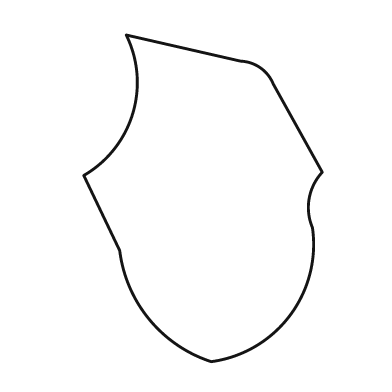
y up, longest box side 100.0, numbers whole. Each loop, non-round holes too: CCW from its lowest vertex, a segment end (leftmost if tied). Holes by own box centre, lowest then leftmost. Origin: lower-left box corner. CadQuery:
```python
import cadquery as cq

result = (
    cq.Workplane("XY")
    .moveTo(39.0, 0.0)
    .threePointArc((63.0, 14.0), (70.0, 41.0))
    .threePointArc((69.0, 50.0), (73.0, 58.0))
    .lineTo(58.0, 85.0)
    .threePointArc((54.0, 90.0), (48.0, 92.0))
    .lineTo(13.0, 100.0)
    .threePointArc((15.0, 76.0), (0.0, 57.0))
    .lineTo(11.0, 34.0)
    .threePointArc((20.0, 13.0), (39.0, 0.0))
    .close()
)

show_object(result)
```